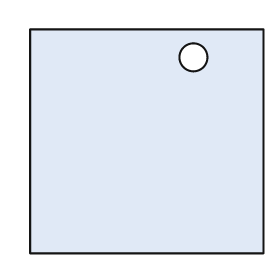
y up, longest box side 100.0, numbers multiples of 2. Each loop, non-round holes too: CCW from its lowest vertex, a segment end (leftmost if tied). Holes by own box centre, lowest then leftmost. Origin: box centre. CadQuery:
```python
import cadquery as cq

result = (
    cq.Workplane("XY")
    .moveTo(-50.0, -48.0)
    .lineTo(50.0, -48.0)
    .lineTo(50.0, 48.0)
    .lineTo(-50.0, 48.0)
    .close()
    .moveTo(20.0, 36.0)
    .circle(6.0)
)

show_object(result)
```